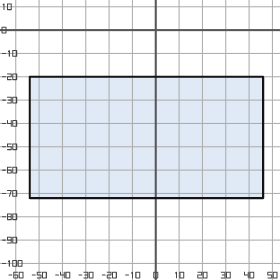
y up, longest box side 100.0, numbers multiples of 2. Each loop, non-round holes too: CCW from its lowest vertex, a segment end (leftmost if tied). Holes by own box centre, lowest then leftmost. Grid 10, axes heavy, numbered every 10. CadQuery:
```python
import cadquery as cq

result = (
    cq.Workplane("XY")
    .moveTo(-54.0, -72.0)
    .lineTo(46.0, -72.0)
    .lineTo(46.0, -20.0)
    .lineTo(-54.0, -20.0)
    .close()
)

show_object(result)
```